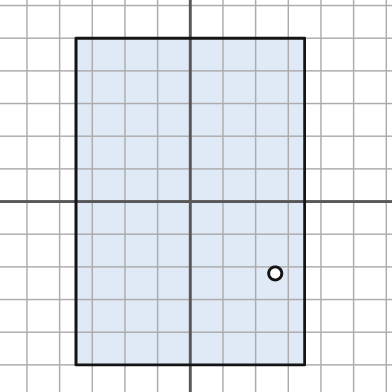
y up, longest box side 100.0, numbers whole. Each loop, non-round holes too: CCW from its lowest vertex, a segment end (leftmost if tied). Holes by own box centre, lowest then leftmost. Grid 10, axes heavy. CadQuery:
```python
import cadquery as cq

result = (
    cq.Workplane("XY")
    .moveTo(-35.0, -50.0)
    .lineTo(35.0, -50.0)
    .lineTo(35.0, 50.0)
    .lineTo(-35.0, 50.0)
    .close()
    .moveTo(26.0, -22.0)
    .circle(2.0)
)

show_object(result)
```